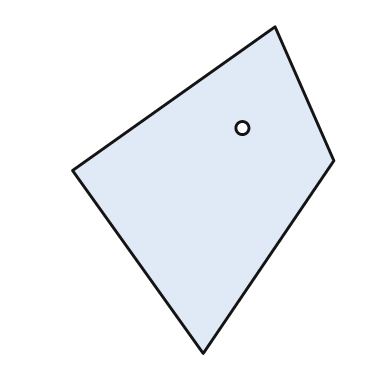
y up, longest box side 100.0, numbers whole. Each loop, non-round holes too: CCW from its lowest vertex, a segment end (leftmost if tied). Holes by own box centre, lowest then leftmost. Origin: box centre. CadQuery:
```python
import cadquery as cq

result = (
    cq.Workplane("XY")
    .moveTo(0.0, -50.0)
    .lineTo(40.0, 9.0)
    .lineTo(22.0, 50.0)
    .lineTo(-40.0, 6.0)
    .close()
    .moveTo(12.0, 19.0)
    .circle(2.0)
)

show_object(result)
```